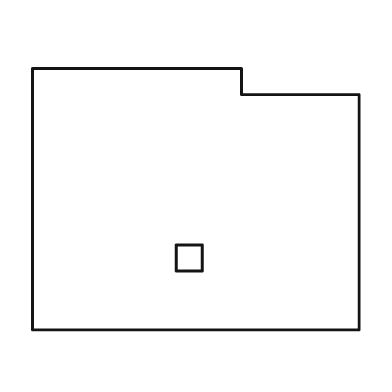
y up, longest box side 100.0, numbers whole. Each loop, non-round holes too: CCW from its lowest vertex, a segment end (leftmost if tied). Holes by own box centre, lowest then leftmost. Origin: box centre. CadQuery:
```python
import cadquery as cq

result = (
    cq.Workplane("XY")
    .moveTo(-50.0, -40.0)
    .lineTo(50.0, -40.0)
    .lineTo(50.0, 32.0)
    .lineTo(14.0, 32.0)
    .lineTo(14.0, 40.0)
    .lineTo(-50.0, 40.0)
    .close()
    .moveTo(-6.0, -22.0)
    .lineTo(2.0, -22.0)
    .lineTo(2.0, -14.0)
    .lineTo(-6.0, -14.0)
    .close()
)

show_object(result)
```